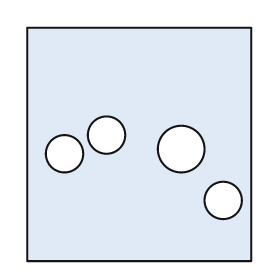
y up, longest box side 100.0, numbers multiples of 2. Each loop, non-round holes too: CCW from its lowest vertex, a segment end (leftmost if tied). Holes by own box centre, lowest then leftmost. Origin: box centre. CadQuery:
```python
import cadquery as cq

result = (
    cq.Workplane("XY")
    .moveTo(-48.0, -50.0)
    .lineTo(48.0, -50.0)
    .lineTo(48.0, 50.0)
    .lineTo(-48.0, 50.0)
    .close()
    .moveTo(36.0, -24.0)
    .circle(8.0)
    .moveTo(-32.0, -4.0)
    .circle(8.0)
    .moveTo(18.0, -2.0)
    .circle(10.0)
    .moveTo(-14.0, 4.0)
    .circle(8.0)
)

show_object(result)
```